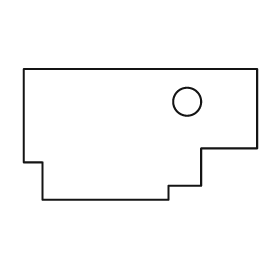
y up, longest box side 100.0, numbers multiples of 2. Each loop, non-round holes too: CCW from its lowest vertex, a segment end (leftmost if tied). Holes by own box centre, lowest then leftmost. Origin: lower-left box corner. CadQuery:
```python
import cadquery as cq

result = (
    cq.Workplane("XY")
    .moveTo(8.0, 0.0)
    .lineTo(62.0, 0.0)
    .lineTo(62.0, 6.0)
    .lineTo(76.0, 6.0)
    .lineTo(76.0, 22.0)
    .lineTo(100.0, 22.0)
    .lineTo(100.0, 56.0)
    .lineTo(0.0, 56.0)
    .lineTo(0.0, 16.0)
    .lineTo(8.0, 16.0)
    .close()
    .moveTo(70.0, 42.0)
    .circle(6.0)
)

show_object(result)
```